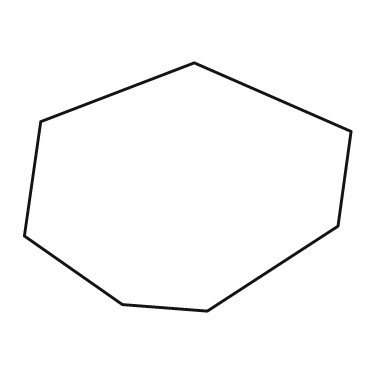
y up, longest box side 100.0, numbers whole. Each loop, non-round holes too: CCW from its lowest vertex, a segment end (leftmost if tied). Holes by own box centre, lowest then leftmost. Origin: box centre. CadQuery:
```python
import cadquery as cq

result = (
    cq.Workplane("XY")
    .moveTo(6.0, -38.0)
    .lineTo(46.0, -12.0)
    .lineTo(50.0, 17.0)
    .lineTo(2.0, 38.0)
    .lineTo(-45.0, 20.0)
    .lineTo(-50.0, -15.0)
    .lineTo(-20.0, -36.0)
    .close()
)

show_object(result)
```